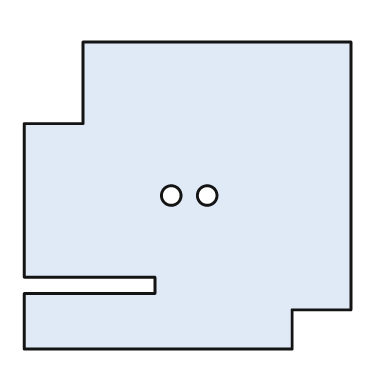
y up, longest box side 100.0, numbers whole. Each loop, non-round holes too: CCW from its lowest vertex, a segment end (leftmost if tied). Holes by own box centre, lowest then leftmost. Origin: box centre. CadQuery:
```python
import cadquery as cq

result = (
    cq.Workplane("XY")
    .moveTo(-50.0, -47.0)
    .lineTo(32.0, -47.0)
    .lineTo(32.0, -35.0)
    .lineTo(50.0, -35.0)
    .lineTo(50.0, 47.0)
    .lineTo(-32.0, 47.0)
    .lineTo(-32.0, 22.0)
    .lineTo(-50.0, 22.0)
    .lineTo(-50.0, -25.0)
    .lineTo(-10.0, -25.0)
    .lineTo(-10.0, -30.0)
    .lineTo(-50.0, -30.0)
    .close()
    .moveTo(-5.0, 0.0)
    .circle(3.0)
    .moveTo(6.0, 0.0)
    .circle(3.0)
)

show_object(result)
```